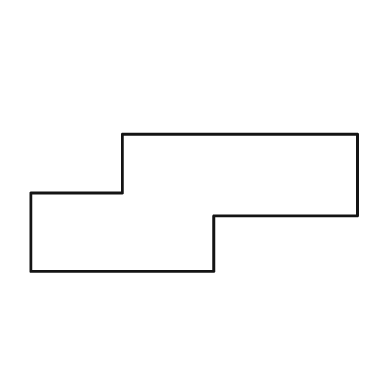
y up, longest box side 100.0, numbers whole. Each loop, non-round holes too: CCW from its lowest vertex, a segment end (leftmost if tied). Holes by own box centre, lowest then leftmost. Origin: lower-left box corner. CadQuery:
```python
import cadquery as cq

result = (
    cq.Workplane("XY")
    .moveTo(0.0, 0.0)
    .lineTo(56.0, 0.0)
    .lineTo(56.0, 17.0)
    .lineTo(100.0, 17.0)
    .lineTo(100.0, 42.0)
    .lineTo(28.0, 42.0)
    .lineTo(28.0, 24.0)
    .lineTo(0.0, 24.0)
    .close()
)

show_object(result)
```